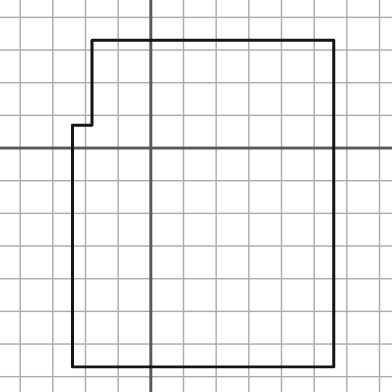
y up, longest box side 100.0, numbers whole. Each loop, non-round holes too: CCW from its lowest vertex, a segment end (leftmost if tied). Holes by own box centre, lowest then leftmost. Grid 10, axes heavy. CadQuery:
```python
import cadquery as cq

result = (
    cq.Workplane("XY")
    .moveTo(-24.0, -67.0)
    .lineTo(56.0, -67.0)
    .lineTo(56.0, 33.0)
    .lineTo(-18.0, 33.0)
    .lineTo(-18.0, 7.0)
    .lineTo(-24.0, 7.0)
    .close()
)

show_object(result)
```